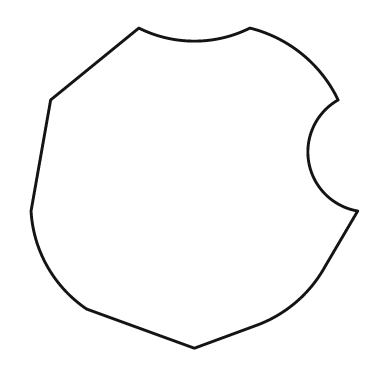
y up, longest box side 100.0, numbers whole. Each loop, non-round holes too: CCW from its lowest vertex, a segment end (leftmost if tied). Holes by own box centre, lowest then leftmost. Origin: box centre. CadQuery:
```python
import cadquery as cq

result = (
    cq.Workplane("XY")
    .moveTo(0.0, -49.0)
    .lineTo(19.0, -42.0)
    .threePointArc((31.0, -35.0), (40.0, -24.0))
    .lineTo(50.0, -7.0)
    .threePointArc((35.0, 8.0), (44.0, 27.0))
    .threePointArc((33.0, 41.0), (17.0, 49.0))
    .threePointArc((0.0, 45.0), (-17.0, 49.0))
    .lineTo(-44.0, 27.0)
    .lineTo(-50.0, -7.0)
    .threePointArc((-45.0, -24.0), (-33.0, -37.0))
    .close()
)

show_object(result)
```